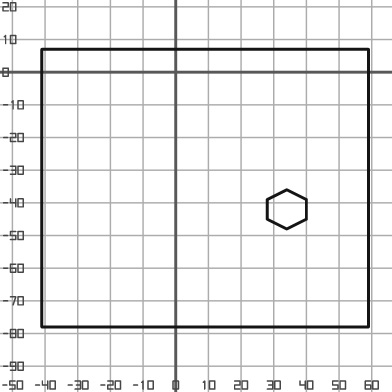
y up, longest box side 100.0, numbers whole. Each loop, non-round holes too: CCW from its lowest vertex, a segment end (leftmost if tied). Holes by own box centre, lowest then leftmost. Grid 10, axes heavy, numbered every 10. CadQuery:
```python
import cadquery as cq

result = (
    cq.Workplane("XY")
    .moveTo(-41.0, -78.0)
    .lineTo(59.0, -78.0)
    .lineTo(59.0, 7.0)
    .lineTo(-41.0, 7.0)
    .close()
    .moveTo(34.0, -48.0)
    .lineTo(40.0, -45.0)
    .lineTo(40.0, -39.0)
    .lineTo(34.0, -36.0)
    .lineTo(28.0, -39.0)
    .lineTo(28.0, -45.0)
    .close()
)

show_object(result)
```